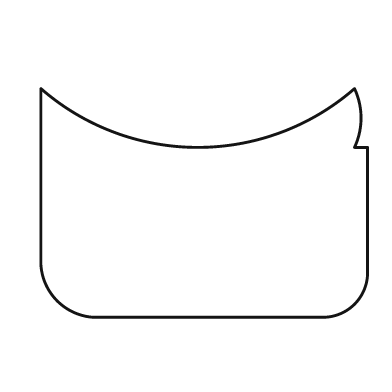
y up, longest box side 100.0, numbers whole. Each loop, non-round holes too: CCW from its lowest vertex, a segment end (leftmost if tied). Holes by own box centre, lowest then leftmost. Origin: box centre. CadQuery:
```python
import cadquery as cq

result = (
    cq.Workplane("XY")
    .moveTo(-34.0, -35.0)
    .lineTo(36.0, -35.0)
    .threePointArc((46.0, -31.0), (50.0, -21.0))
    .lineTo(50.0, 17.0)
    .lineTo(46.0, 17.0)
    .threePointArc((48.0, 26.0), (46.0, 35.0))
    .threePointArc((-2.0, 17.0), (-50.0, 35.0))
    .lineTo(-50.0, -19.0)
    .threePointArc((-45.0, -30.0), (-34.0, -35.0))
    .close()
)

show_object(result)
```